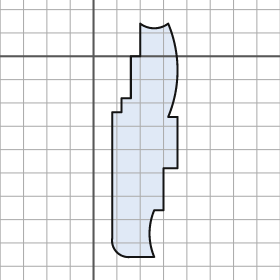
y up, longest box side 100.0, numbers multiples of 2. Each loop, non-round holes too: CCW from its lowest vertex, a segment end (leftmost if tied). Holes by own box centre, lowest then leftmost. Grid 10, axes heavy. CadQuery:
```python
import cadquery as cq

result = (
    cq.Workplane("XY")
    .moveTo(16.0, -86.0)
    .lineTo(26.0, -86.0)
    .threePointArc((24.0, -76.0), (26.0, -66.0))
    .lineTo(30.0, -66.0)
    .lineTo(30.0, -48.0)
    .lineTo(36.0, -48.0)
    .lineTo(36.0, -26.0)
    .lineTo(32.0, -26.0)
    .threePointArc((36.0, -6.0), (32.0, 14.0))
    .threePointArc((26.0, 12.0), (20.0, 14.0))
    .lineTo(20.0, 0.0)
    .lineTo(16.0, 0.0)
    .lineTo(16.0, -18.0)
    .lineTo(12.0, -18.0)
    .lineTo(12.0, -24.0)
    .lineTo(8.0, -24.0)
    .lineTo(8.0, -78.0)
    .threePointArc((10.0, -84.0), (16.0, -86.0))
    .close()
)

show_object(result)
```